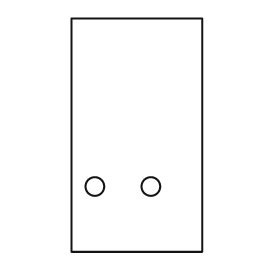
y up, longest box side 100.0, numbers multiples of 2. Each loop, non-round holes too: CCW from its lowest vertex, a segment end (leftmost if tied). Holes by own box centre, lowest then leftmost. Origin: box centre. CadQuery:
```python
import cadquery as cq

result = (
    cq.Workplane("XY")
    .moveTo(-28.0, -50.0)
    .lineTo(28.0, -50.0)
    .lineTo(28.0, 50.0)
    .lineTo(-28.0, 50.0)
    .close()
    .moveTo(-18.0, -22.0)
    .circle(4.0)
    .moveTo(6.0, -22.0)
    .circle(4.0)
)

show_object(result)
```